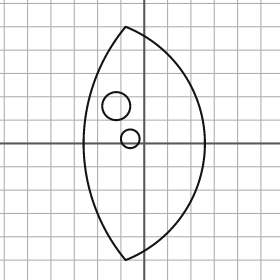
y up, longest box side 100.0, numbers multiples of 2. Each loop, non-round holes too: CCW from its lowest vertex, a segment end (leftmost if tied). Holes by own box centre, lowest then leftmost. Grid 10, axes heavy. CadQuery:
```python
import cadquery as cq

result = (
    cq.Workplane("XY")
    .moveTo(-8.0, -50.0)
    .threePointArc((26.0, 0.0), (-8.0, 50.0))
    .threePointArc((-26.0, 0.0), (-8.0, -50.0))
    .close()
    .moveTo(-6.0, 2.0)
    .circle(4.0)
    .moveTo(-12.0, 16.0)
    .circle(6.0)
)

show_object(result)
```